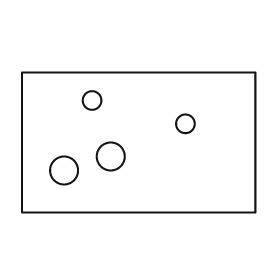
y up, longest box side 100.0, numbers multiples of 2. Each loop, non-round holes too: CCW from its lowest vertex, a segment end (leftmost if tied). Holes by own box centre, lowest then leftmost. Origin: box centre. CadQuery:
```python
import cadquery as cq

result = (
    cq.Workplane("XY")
    .moveTo(-50.0, -30.0)
    .lineTo(50.0, -30.0)
    .lineTo(50.0, 30.0)
    .lineTo(-50.0, 30.0)
    .close()
    .moveTo(-32.0, -12.0)
    .circle(6.0)
    .moveTo(-12.0, -6.0)
    .circle(6.0)
    .moveTo(20.0, 8.0)
    .circle(4.0)
    .moveTo(-20.0, 18.0)
    .circle(4.0)
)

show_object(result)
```